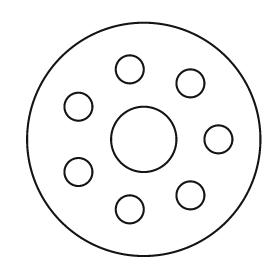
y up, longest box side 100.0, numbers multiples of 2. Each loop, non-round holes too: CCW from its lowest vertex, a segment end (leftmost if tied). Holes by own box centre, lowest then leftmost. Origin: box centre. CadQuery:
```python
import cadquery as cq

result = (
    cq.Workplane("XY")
    .moveTo(0.0, 0.0)
    .circle(50.0)
    .moveTo(-6.0, -30.0)
    .circle(6.0)
    .moveTo(20.0, -24.0)
    .circle(6.0)
    .moveTo(-28.0, -14.0)
    .circle(6.0)
    .moveTo(0.0, 0.0)
    .circle(14.0)
    .moveTo(32.0, 0.0)
    .circle(6.0)
    .moveTo(-28.0, 14.0)
    .circle(6.0)
    .moveTo(20.0, 24.0)
    .circle(6.0)
    .moveTo(-6.0, 30.0)
    .circle(6.0)
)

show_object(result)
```